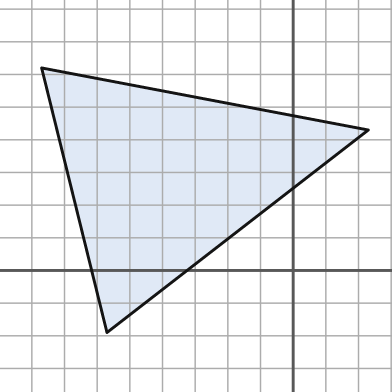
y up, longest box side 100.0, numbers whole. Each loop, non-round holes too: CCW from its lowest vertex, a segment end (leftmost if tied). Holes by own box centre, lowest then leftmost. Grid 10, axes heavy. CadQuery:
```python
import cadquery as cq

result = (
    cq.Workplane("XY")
    .moveTo(-57.0, -19.0)
    .lineTo(23.0, 43.0)
    .lineTo(-77.0, 62.0)
    .close()
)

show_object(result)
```